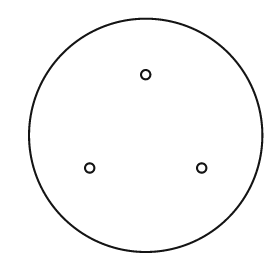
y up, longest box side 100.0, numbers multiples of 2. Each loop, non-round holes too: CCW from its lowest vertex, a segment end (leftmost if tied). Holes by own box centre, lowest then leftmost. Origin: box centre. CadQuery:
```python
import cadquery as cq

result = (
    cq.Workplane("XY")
    .moveTo(0.0, 0.0)
    .circle(50.0)
    .moveTo(-24.0, -14.0)
    .circle(2.0)
    .moveTo(24.0, -14.0)
    .circle(2.0)
    .moveTo(0.0, 26.0)
    .circle(2.0)
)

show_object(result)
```